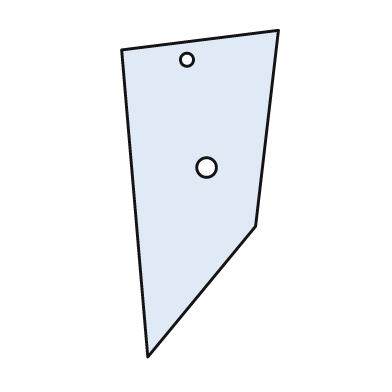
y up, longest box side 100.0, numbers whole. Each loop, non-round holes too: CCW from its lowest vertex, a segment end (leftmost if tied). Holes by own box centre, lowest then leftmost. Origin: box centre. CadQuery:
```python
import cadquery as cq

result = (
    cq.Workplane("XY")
    .moveTo(-16.0, -50.0)
    .lineTo(17.0, -10.0)
    .lineTo(24.0, 50.0)
    .lineTo(-24.0, 44.0)
    .close()
    .moveTo(2.0, 8.0)
    .circle(3.0)
    .moveTo(-4.0, 41.0)
    .circle(2.0)
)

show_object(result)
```